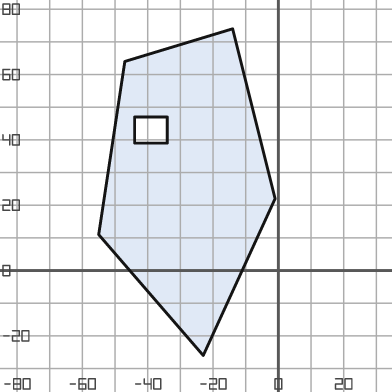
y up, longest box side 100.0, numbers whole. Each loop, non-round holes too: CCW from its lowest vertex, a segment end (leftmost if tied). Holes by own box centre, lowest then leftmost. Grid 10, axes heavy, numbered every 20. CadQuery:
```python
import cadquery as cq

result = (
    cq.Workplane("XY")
    .moveTo(-23.0, -26.0)
    .lineTo(-1.0, 22.0)
    .lineTo(-14.0, 74.0)
    .lineTo(-47.0, 64.0)
    .lineTo(-55.0, 11.0)
    .close()
    .moveTo(-44.0, 39.0)
    .lineTo(-34.0, 39.0)
    .lineTo(-34.0, 47.0)
    .lineTo(-44.0, 47.0)
    .close()
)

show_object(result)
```